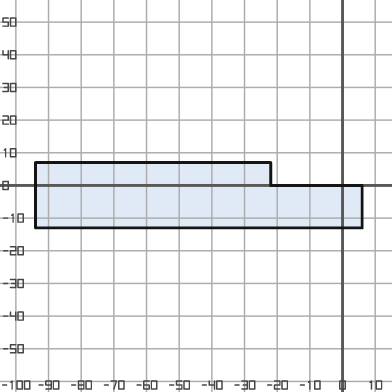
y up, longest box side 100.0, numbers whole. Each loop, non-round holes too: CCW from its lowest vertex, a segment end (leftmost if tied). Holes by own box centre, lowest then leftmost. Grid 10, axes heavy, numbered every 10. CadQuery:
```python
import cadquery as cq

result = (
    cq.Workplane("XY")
    .moveTo(-94.0, -13.0)
    .lineTo(6.0, -13.0)
    .lineTo(6.0, 0.0)
    .lineTo(-22.0, 0.0)
    .lineTo(-22.0, 7.0)
    .lineTo(-94.0, 7.0)
    .close()
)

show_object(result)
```